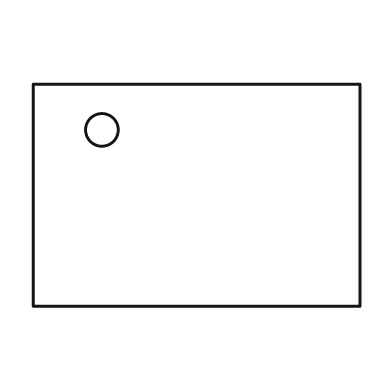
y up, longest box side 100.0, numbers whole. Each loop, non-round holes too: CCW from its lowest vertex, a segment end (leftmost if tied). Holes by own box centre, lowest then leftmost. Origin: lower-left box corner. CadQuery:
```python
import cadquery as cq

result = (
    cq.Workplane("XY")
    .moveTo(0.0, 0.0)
    .lineTo(100.0, 0.0)
    .lineTo(100.0, 68.0)
    .lineTo(0.0, 68.0)
    .close()
    .moveTo(21.0, 54.0)
    .circle(5.0)
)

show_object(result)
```